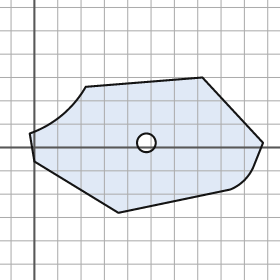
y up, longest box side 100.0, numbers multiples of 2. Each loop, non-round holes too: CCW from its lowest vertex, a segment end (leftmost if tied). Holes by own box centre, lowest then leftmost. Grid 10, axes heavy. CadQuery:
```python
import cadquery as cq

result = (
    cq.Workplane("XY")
    .moveTo(36.0, -28.0)
    .lineTo(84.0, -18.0)
    .threePointArc((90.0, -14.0), (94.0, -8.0))
    .lineTo(98.0, 2.0)
    .lineTo(72.0, 30.0)
    .lineTo(22.0, 26.0)
    .threePointArc((12.0, 14.0), (-2.0, 6.0))
    .lineTo(0.0, -6.0)
    .close()
    .moveTo(48.0, 2.0)
    .circle(4.0)
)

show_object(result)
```